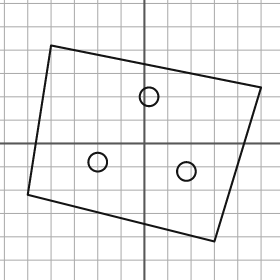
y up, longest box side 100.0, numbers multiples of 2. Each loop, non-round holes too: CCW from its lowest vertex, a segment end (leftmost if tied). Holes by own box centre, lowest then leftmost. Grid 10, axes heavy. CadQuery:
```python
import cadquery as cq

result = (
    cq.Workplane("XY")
    .moveTo(30.0, -42.0)
    .lineTo(50.0, 24.0)
    .lineTo(-40.0, 42.0)
    .lineTo(-50.0, -22.0)
    .close()
    .moveTo(18.0, -12.0)
    .circle(4.0)
    .moveTo(-20.0, -8.0)
    .circle(4.0)
    .moveTo(2.0, 20.0)
    .circle(4.0)
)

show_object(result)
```